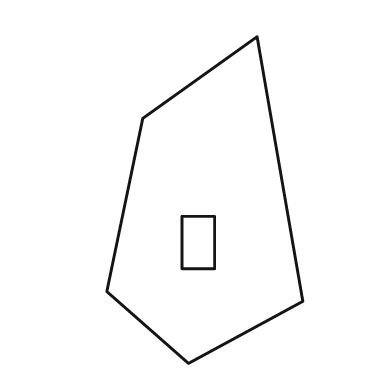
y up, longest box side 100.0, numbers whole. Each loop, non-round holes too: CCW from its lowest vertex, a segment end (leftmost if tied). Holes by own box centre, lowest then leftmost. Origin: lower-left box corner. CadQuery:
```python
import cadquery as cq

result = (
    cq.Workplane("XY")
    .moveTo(25.0, 0.0)
    .lineTo(60.0, 19.0)
    .lineTo(46.0, 100.0)
    .lineTo(11.0, 75.0)
    .lineTo(0.0, 22.0)
    .close()
    .moveTo(23.0, 29.0)
    .lineTo(33.0, 29.0)
    .lineTo(33.0, 45.0)
    .lineTo(23.0, 45.0)
    .close()
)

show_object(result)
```